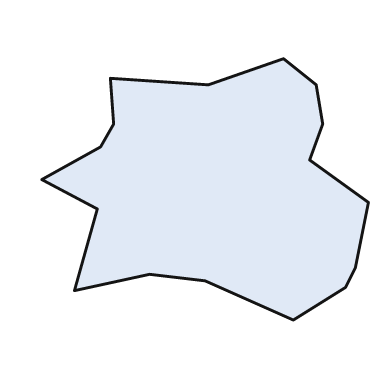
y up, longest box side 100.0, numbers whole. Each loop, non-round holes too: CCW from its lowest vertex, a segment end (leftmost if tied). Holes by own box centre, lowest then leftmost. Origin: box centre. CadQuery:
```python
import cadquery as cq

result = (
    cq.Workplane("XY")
    .moveTo(27.0, -40.0)
    .lineTo(43.0, -30.0)
    .lineTo(46.0, -24.0)
    .lineTo(50.0, -4.0)
    .lineTo(32.0, 9.0)
    .lineTo(36.0, 20.0)
    .lineTo(34.0, 32.0)
    .lineTo(24.0, 40.0)
    .lineTo(1.0, 32.0)
    .lineTo(-29.0, 34.0)
    .lineTo(-28.0, 20.0)
    .lineTo(-32.0, 13.0)
    .lineTo(-50.0, 3.0)
    .lineTo(-33.0, -6.0)
    .lineTo(-40.0, -31.0)
    .lineTo(-17.0, -26.0)
    .lineTo(0.0, -28.0)
    .close()
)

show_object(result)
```